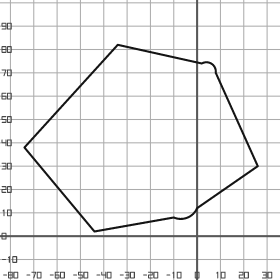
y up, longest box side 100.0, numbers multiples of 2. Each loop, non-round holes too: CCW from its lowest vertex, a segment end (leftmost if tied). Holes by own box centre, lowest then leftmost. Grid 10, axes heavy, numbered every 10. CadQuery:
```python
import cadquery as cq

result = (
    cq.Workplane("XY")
    .moveTo(-44.0, 2.0)
    .lineTo(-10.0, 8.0)
    .threePointArc((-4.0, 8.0), (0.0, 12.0))
    .lineTo(26.0, 30.0)
    .lineTo(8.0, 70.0)
    .threePointArc((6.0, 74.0), (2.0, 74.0))
    .lineTo(-34.0, 82.0)
    .lineTo(-74.0, 38.0)
    .close()
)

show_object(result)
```